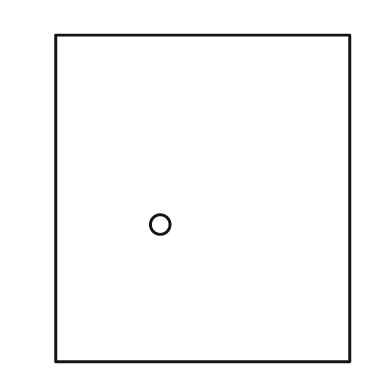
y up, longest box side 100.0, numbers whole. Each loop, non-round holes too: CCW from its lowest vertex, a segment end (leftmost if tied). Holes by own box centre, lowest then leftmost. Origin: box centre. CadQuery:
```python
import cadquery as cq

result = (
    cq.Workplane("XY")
    .moveTo(-45.0, -50.0)
    .lineTo(45.0, -50.0)
    .lineTo(45.0, 50.0)
    .lineTo(-45.0, 50.0)
    .close()
    .moveTo(-13.0, -8.0)
    .circle(3.0)
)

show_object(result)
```